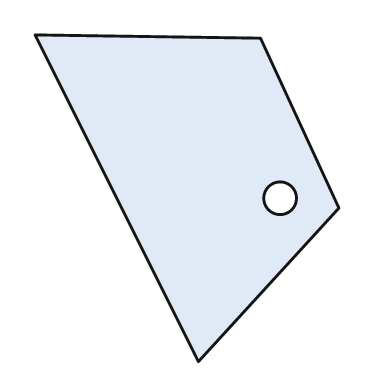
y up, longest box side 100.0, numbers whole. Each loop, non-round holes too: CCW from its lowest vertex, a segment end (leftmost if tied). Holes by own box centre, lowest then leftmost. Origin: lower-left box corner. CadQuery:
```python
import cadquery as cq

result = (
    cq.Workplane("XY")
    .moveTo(50.0, 0.0)
    .lineTo(93.0, 47.0)
    .lineTo(69.0, 99.0)
    .lineTo(0.0, 100.0)
    .close()
    .moveTo(75.0, 50.0)
    .circle(5.0)
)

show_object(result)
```